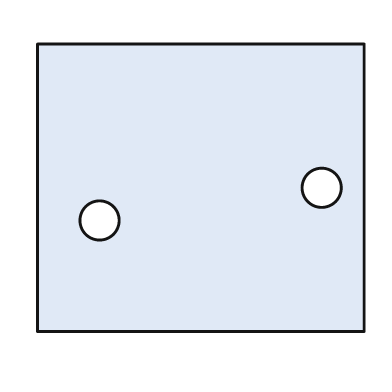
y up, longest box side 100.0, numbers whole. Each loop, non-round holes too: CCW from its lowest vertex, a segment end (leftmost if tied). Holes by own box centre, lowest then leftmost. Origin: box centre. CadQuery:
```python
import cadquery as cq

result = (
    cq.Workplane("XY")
    .moveTo(-50.0, -44.0)
    .lineTo(50.0, -44.0)
    .lineTo(50.0, 44.0)
    .lineTo(-50.0, 44.0)
    .close()
    .moveTo(-31.0, -10.0)
    .circle(6.0)
    .moveTo(37.0, 0.0)
    .circle(6.0)
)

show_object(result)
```